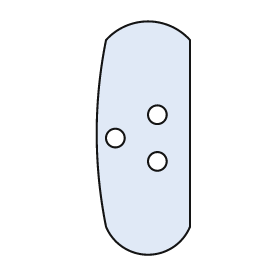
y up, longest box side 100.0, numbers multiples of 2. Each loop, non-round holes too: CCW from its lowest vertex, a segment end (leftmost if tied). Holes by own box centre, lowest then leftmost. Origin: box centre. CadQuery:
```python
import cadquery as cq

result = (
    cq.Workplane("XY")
    .moveTo(-16.0, -38.0)
    .threePointArc((2.0, -50.0), (20.0, -38.0))
    .lineTo(20.0, 42.0)
    .threePointArc((2.0, 50.0), (-16.0, 42.0))
    .threePointArc((-20.0, 2.0), (-16.0, -38.0))
    .close()
    .moveTo(6.0, -10.0)
    .circle(4.0)
    .moveTo(-12.0, 0.0)
    .circle(4.0)
    .moveTo(6.0, 10.0)
    .circle(4.0)
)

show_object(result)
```